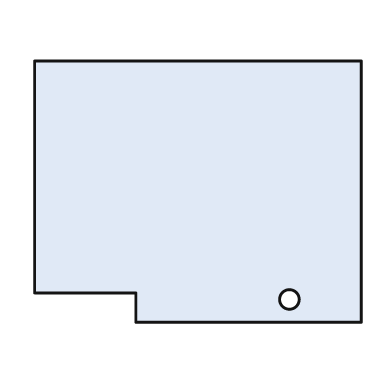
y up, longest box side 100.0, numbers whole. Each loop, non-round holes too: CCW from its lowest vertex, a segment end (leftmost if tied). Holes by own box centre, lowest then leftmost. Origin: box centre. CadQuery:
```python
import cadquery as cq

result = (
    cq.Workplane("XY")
    .moveTo(-19.0, -40.0)
    .lineTo(50.0, -40.0)
    .lineTo(50.0, 40.0)
    .lineTo(-50.0, 40.0)
    .lineTo(-50.0, -31.0)
    .lineTo(-19.0, -31.0)
    .close()
    .moveTo(28.0, -33.0)
    .circle(3.0)
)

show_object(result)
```